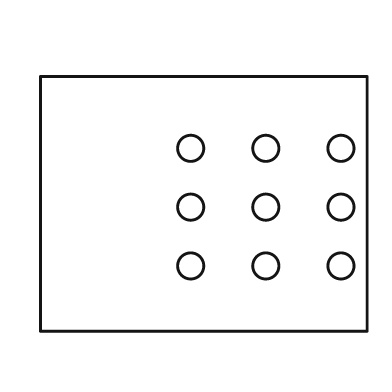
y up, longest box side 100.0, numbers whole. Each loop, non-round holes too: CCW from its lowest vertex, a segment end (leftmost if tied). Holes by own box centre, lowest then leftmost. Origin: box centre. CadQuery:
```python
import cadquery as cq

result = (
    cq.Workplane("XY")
    .moveTo(-50.0, -39.0)
    .lineTo(50.0, -39.0)
    .lineTo(50.0, 39.0)
    .lineTo(-50.0, 39.0)
    .close()
    .moveTo(-4.0, -19.0)
    .circle(4.0)
    .moveTo(19.0, -19.0)
    .circle(4.0)
    .moveTo(42.0, -19.0)
    .circle(4.0)
    .moveTo(-4.0, -1.0)
    .circle(4.0)
    .moveTo(19.0, -1.0)
    .circle(4.0)
    .moveTo(42.0, -1.0)
    .circle(4.0)
    .moveTo(-4.0, 17.0)
    .circle(4.0)
    .moveTo(19.0, 17.0)
    .circle(4.0)
    .moveTo(42.0, 17.0)
    .circle(4.0)
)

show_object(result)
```